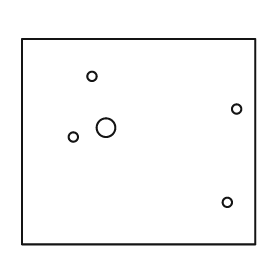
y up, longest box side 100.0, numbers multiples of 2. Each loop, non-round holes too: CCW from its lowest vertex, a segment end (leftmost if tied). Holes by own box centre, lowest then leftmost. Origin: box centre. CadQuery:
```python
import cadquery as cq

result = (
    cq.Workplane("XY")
    .moveTo(-50.0, -44.0)
    .lineTo(50.0, -44.0)
    .lineTo(50.0, 44.0)
    .lineTo(-50.0, 44.0)
    .close()
    .moveTo(38.0, -26.0)
    .circle(2.0)
    .moveTo(-28.0, 2.0)
    .circle(2.0)
    .moveTo(-14.0, 6.0)
    .circle(4.0)
    .moveTo(42.0, 14.0)
    .circle(2.0)
    .moveTo(-20.0, 28.0)
    .circle(2.0)
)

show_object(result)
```